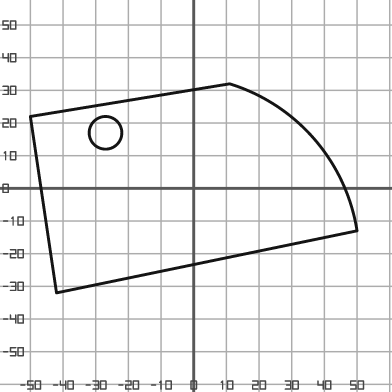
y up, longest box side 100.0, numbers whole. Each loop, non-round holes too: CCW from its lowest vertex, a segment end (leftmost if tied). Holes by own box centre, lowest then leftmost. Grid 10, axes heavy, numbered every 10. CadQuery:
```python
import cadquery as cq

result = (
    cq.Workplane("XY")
    .moveTo(-42.0, -32.0)
    .lineTo(50.0, -13.0)
    .threePointArc((37.0, 15.0), (11.0, 32.0))
    .lineTo(-50.0, 22.0)
    .close()
    .moveTo(-27.0, 17.0)
    .circle(5.0)
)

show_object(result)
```